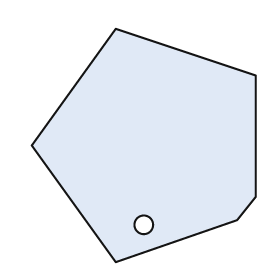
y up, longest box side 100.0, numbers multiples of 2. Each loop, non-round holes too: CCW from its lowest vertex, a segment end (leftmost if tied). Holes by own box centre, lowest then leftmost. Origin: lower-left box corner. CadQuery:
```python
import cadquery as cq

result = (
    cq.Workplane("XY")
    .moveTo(36.0, 0.0)
    .lineTo(88.0, 18.0)
    .lineTo(96.0, 28.0)
    .lineTo(96.0, 80.0)
    .lineTo(36.0, 100.0)
    .lineTo(0.0, 50.0)
    .close()
    .moveTo(48.0, 16.0)
    .circle(4.0)
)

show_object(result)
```